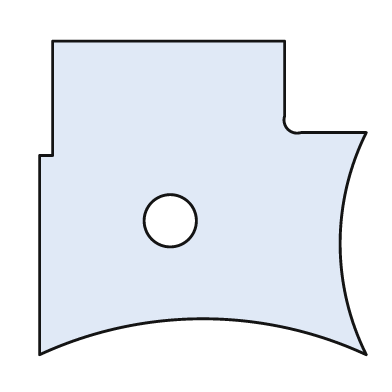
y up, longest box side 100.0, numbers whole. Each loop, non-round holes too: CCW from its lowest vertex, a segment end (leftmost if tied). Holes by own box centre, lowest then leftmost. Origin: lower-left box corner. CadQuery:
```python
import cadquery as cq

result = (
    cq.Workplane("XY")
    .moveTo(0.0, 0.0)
    .threePointArc((50.0, 11.0), (100.0, 0.0))
    .threePointArc((92.0, 34.0), (100.0, 68.0))
    .lineTo(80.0, 68.0)
    .threePointArc((76.0, 69.0), (75.0, 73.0))
    .lineTo(75.0, 96.0)
    .lineTo(4.0, 96.0)
    .lineTo(4.0, 61.0)
    .lineTo(0.0, 61.0)
    .close()
    .moveTo(40.0, 41.0)
    .circle(8.0)
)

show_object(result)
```